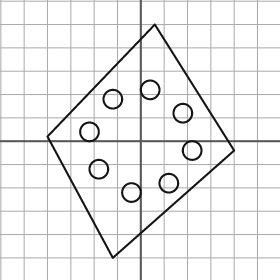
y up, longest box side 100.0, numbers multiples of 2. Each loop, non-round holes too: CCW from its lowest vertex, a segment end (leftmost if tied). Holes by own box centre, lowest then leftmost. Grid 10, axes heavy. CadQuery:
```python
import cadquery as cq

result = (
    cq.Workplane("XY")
    .moveTo(-12.0, -50.0)
    .lineTo(40.0, -4.0)
    .lineTo(6.0, 50.0)
    .lineTo(-40.0, 2.0)
    .close()
    .moveTo(-4.0, -22.0)
    .circle(4.0)
    .moveTo(12.0, -18.0)
    .circle(4.0)
    .moveTo(-18.0, -12.0)
    .circle(4.0)
    .moveTo(22.0, -4.0)
    .circle(4.0)
    .moveTo(-22.0, 4.0)
    .circle(4.0)
    .moveTo(18.0, 12.0)
    .circle(4.0)
    .moveTo(-12.0, 18.0)
    .circle(4.0)
    .moveTo(4.0, 22.0)
    .circle(4.0)
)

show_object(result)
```